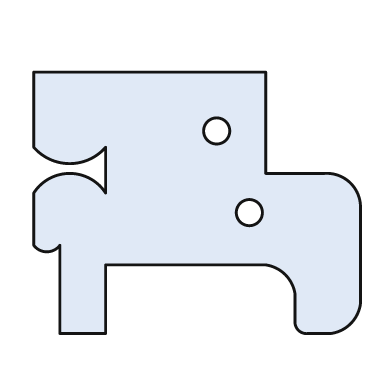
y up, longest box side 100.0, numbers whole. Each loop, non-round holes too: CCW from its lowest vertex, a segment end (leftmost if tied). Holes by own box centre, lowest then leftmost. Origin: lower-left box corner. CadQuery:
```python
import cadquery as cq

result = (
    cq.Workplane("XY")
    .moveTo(8.0, 0.0)
    .lineTo(22.0, 0.0)
    .lineTo(22.0, 21.0)
    .lineTo(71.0, 21.0)
    .threePointArc((77.0, 18.0), (80.0, 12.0))
    .lineTo(80.0, 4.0)
    .threePointArc((81.0, 1.0), (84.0, 0.0))
    .lineTo(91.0, 0.0)
    .threePointArc((97.0, 3.0), (100.0, 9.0))
    .lineTo(100.0, 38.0)
    .threePointArc((97.0, 46.0), (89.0, 49.0))
    .lineTo(71.0, 49.0)
    .lineTo(71.0, 80.0)
    .lineTo(0.0, 80.0)
    .lineTo(0.0, 57.0)
    .threePointArc((11.0, 52.0), (22.0, 57.0))
    .lineTo(22.0, 43.0)
    .threePointArc((11.0, 49.0), (0.0, 43.0))
    .lineTo(0.0, 27.0)
    .threePointArc((4.0, 25.0), (8.0, 27.0))
    .close()
    .moveTo(66.0, 37.0)
    .circle(4.0)
    .moveTo(56.0, 62.0)
    .circle(4.0)
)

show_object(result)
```